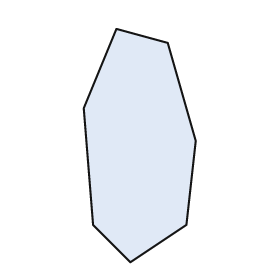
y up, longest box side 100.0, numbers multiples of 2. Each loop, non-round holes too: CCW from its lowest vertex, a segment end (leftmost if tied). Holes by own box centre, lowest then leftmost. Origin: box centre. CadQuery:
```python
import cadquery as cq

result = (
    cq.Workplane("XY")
    .moveTo(-4.0, -50.0)
    .lineTo(20.0, -34.0)
    .lineTo(24.0, 2.0)
    .lineTo(12.0, 44.0)
    .lineTo(-10.0, 50.0)
    .lineTo(-24.0, 16.0)
    .lineTo(-20.0, -34.0)
    .close()
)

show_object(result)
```